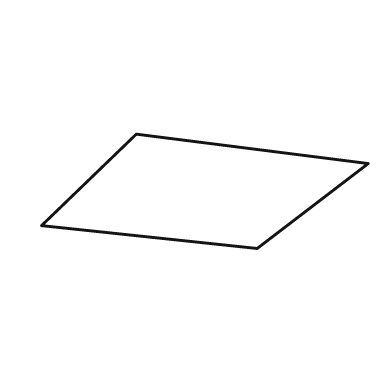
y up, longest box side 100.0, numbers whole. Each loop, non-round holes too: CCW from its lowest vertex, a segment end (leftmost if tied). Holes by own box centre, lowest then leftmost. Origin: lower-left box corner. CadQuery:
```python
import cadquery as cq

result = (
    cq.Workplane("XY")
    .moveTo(66.0, 0.0)
    .lineTo(100.0, 26.0)
    .lineTo(29.0, 35.0)
    .lineTo(0.0, 7.0)
    .close()
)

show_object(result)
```